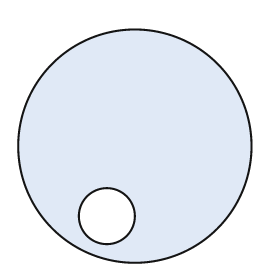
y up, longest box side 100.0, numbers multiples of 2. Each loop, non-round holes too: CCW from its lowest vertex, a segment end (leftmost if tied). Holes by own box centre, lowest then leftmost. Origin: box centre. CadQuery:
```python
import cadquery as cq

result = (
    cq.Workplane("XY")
    .moveTo(0.0, 0.0)
    .circle(50.0)
    .moveTo(-12.0, -30.0)
    .circle(12.0)
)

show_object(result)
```